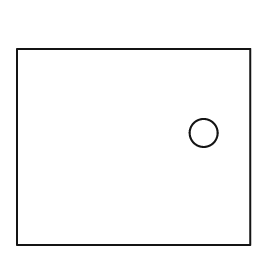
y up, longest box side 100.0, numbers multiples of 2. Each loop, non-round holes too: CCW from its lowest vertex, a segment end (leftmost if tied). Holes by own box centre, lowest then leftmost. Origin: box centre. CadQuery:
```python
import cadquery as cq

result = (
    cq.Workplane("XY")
    .moveTo(-50.0, -42.0)
    .lineTo(50.0, -42.0)
    .lineTo(50.0, 42.0)
    .lineTo(-50.0, 42.0)
    .close()
    .moveTo(30.0, 6.0)
    .circle(6.0)
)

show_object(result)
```